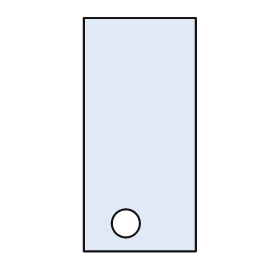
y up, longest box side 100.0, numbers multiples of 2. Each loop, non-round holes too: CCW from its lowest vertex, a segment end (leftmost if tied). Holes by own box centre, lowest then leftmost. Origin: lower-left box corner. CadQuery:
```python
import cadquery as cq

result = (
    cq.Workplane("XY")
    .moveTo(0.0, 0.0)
    .lineTo(48.0, 0.0)
    .lineTo(48.0, 100.0)
    .lineTo(0.0, 100.0)
    .close()
    .moveTo(18.0, 12.0)
    .circle(6.0)
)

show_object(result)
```